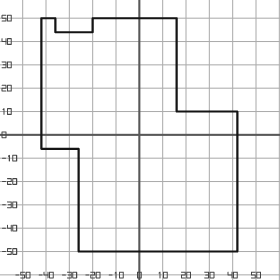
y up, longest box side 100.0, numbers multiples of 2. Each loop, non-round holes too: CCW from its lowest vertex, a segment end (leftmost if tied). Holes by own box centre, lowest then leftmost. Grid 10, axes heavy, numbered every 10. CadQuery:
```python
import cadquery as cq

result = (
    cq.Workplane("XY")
    .moveTo(-26.0, -50.0)
    .lineTo(42.0, -50.0)
    .lineTo(42.0, 10.0)
    .lineTo(16.0, 10.0)
    .lineTo(16.0, 50.0)
    .lineTo(-20.0, 50.0)
    .lineTo(-20.0, 44.0)
    .lineTo(-36.0, 44.0)
    .lineTo(-36.0, 50.0)
    .lineTo(-42.0, 50.0)
    .lineTo(-42.0, -6.0)
    .lineTo(-26.0, -6.0)
    .close()
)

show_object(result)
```